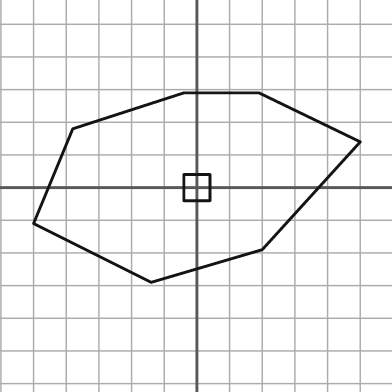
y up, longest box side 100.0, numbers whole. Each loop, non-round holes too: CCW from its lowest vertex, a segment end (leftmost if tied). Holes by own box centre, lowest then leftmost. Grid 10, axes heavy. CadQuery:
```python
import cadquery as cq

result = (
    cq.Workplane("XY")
    .moveTo(-14.0, -29.0)
    .lineTo(20.0, -19.0)
    .lineTo(50.0, 14.0)
    .lineTo(19.0, 29.0)
    .lineTo(-4.0, 29.0)
    .lineTo(-38.0, 18.0)
    .lineTo(-50.0, -11.0)
    .close()
    .moveTo(-4.0, -4.0)
    .lineTo(4.0, -4.0)
    .lineTo(4.0, 4.0)
    .lineTo(-4.0, 4.0)
    .close()
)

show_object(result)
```